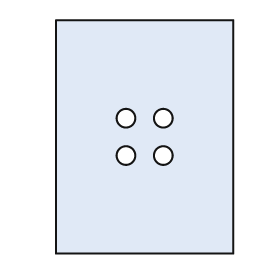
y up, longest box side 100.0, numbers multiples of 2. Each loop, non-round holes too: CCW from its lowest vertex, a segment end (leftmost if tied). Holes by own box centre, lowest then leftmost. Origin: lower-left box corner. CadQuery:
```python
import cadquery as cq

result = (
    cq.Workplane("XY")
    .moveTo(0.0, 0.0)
    .lineTo(76.0, 0.0)
    .lineTo(76.0, 100.0)
    .lineTo(0.0, 100.0)
    .close()
    .moveTo(30.0, 42.0)
    .circle(4.0)
    .moveTo(46.0, 42.0)
    .circle(4.0)
    .moveTo(30.0, 58.0)
    .circle(4.0)
    .moveTo(46.0, 58.0)
    .circle(4.0)
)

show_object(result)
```